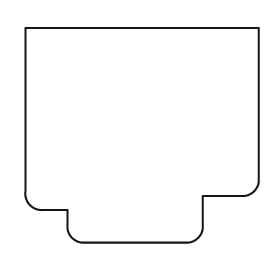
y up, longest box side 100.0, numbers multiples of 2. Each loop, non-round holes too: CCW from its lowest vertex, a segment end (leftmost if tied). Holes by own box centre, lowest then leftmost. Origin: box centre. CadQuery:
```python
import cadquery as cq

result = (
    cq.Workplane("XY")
    .moveTo(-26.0, -46.0)
    .lineTo(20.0, -46.0)
    .threePointArc((24.0, -44.0), (26.0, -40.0))
    .lineTo(26.0, -26.0)
    .lineTo(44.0, -26.0)
    .threePointArc((48.0, -24.0), (50.0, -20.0))
    .lineTo(50.0, 46.0)
    .lineTo(-50.0, 46.0)
    .lineTo(-50.0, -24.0)
    .threePointArc((-48.0, -30.0), (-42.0, -32.0))
    .lineTo(-32.0, -32.0)
    .lineTo(-32.0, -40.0)
    .threePointArc((-30.0, -44.0), (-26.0, -46.0))
    .close()
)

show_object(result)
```